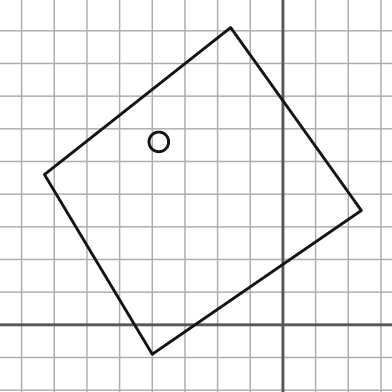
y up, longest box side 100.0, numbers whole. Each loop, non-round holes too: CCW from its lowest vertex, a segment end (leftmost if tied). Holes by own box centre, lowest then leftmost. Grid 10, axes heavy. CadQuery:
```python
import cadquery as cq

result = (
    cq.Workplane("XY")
    .moveTo(-40.0, -9.0)
    .lineTo(24.0, 35.0)
    .lineTo(-16.0, 91.0)
    .lineTo(-73.0, 46.0)
    .close()
    .moveTo(-38.0, 56.0)
    .circle(3.0)
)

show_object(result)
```